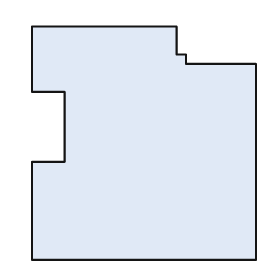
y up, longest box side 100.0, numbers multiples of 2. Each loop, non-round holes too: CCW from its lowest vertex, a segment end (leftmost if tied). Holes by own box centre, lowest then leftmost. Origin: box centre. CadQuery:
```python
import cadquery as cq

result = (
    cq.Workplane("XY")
    .moveTo(-48.0, -50.0)
    .lineTo(48.0, -50.0)
    .lineTo(48.0, 34.0)
    .lineTo(18.0, 34.0)
    .lineTo(18.0, 38.0)
    .lineTo(14.0, 38.0)
    .lineTo(14.0, 50.0)
    .lineTo(-48.0, 50.0)
    .lineTo(-48.0, 22.0)
    .lineTo(-34.0, 22.0)
    .lineTo(-34.0, -8.0)
    .lineTo(-48.0, -8.0)
    .close()
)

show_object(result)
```